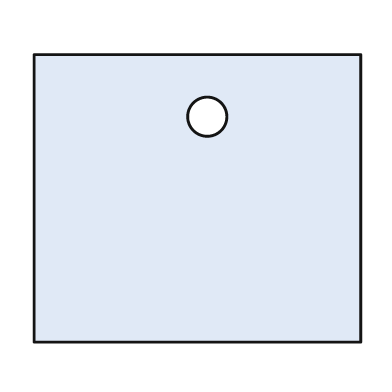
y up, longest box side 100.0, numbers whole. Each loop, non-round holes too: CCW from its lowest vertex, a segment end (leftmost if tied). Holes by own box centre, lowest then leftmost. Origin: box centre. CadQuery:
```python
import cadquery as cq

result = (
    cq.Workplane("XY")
    .moveTo(-50.0, -44.0)
    .lineTo(50.0, -44.0)
    .lineTo(50.0, 44.0)
    .lineTo(-50.0, 44.0)
    .close()
    .moveTo(3.0, 25.0)
    .circle(6.0)
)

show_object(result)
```